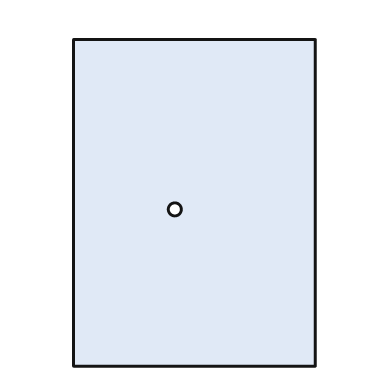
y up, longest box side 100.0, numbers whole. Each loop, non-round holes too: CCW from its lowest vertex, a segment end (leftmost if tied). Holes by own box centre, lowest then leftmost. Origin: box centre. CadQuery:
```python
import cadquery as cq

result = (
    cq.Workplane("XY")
    .moveTo(-37.0, -50.0)
    .lineTo(37.0, -50.0)
    .lineTo(37.0, 50.0)
    .lineTo(-37.0, 50.0)
    .close()
    .moveTo(-6.0, -2.0)
    .circle(2.0)
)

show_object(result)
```